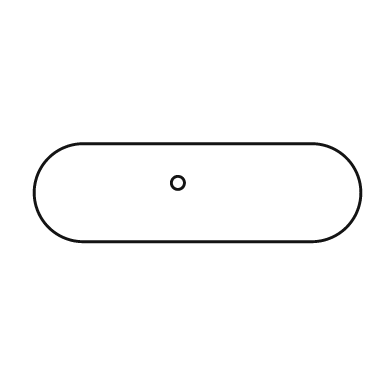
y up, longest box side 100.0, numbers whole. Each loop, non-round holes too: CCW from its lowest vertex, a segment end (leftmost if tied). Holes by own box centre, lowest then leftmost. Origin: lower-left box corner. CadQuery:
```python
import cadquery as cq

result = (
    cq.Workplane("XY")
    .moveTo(15.0, 0.0)
    .lineTo(85.0, 0.0)
    .threePointArc((100.0, 15.0), (85.0, 30.0))
    .lineTo(15.0, 30.0)
    .threePointArc((0.0, 15.0), (15.0, 0.0))
    .close()
    .moveTo(44.0, 18.0)
    .circle(2.0)
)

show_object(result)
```